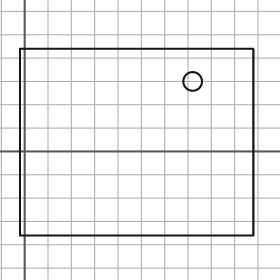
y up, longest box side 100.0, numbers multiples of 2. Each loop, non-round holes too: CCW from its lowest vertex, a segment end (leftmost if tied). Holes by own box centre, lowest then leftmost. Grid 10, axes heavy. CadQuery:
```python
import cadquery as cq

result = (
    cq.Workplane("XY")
    .moveTo(-2.0, -36.0)
    .lineTo(98.0, -36.0)
    .lineTo(98.0, 44.0)
    .lineTo(-2.0, 44.0)
    .close()
    .moveTo(72.0, 30.0)
    .circle(4.0)
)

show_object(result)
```